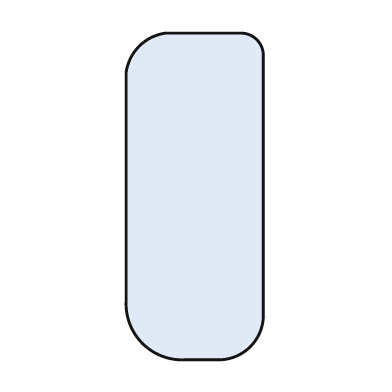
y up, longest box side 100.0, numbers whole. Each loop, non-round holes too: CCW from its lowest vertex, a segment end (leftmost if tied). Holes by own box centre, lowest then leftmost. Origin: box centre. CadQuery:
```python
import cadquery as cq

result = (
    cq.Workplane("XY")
    .moveTo(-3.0, -50.0)
    .lineTo(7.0, -50.0)
    .threePointArc((17.0, -46.0), (21.0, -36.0))
    .lineTo(21.0, 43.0)
    .threePointArc((19.0, 48.0), (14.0, 50.0))
    .lineTo(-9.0, 50.0)
    .threePointArc((-17.0, 46.0), (-21.0, 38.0))
    .lineTo(-21.0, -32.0)
    .threePointArc((-16.0, -45.0), (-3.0, -50.0))
    .close()
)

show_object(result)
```